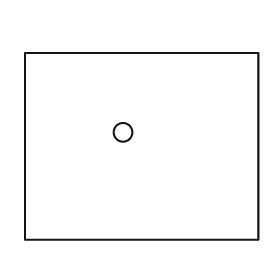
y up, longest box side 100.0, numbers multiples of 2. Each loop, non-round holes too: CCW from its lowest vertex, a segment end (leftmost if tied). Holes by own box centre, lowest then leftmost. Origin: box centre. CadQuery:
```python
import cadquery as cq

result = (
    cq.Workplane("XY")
    .moveTo(-50.0, -40.0)
    .lineTo(50.0, -40.0)
    .lineTo(50.0, 40.0)
    .lineTo(-50.0, 40.0)
    .close()
    .moveTo(-8.0, 6.0)
    .circle(4.0)
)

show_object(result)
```